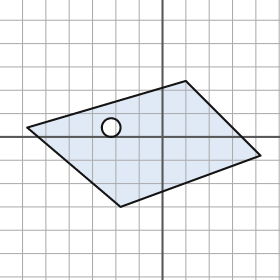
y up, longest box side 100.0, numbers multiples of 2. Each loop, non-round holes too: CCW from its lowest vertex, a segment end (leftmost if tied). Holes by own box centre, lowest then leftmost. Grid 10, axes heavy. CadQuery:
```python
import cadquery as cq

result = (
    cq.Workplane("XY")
    .moveTo(-18.0, -30.0)
    .lineTo(42.0, -8.0)
    .lineTo(10.0, 24.0)
    .lineTo(-58.0, 4.0)
    .close()
    .moveTo(-22.0, 4.0)
    .circle(4.0)
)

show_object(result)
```